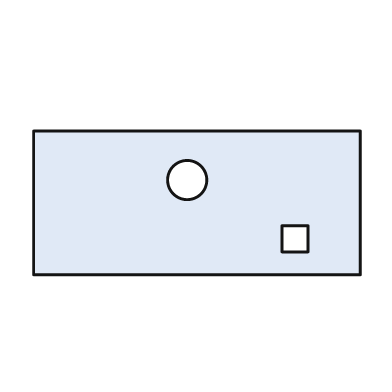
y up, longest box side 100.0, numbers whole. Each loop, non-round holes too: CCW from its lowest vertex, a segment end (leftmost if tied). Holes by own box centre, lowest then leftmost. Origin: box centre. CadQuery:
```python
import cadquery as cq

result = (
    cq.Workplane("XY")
    .moveTo(-50.0, -22.0)
    .lineTo(50.0, -22.0)
    .lineTo(50.0, 22.0)
    .lineTo(-50.0, 22.0)
    .close()
    .moveTo(26.0, -15.0)
    .lineTo(34.0, -15.0)
    .lineTo(34.0, -7.0)
    .lineTo(26.0, -7.0)
    .close()
    .moveTo(-3.0, 7.0)
    .circle(6.0)
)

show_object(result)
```